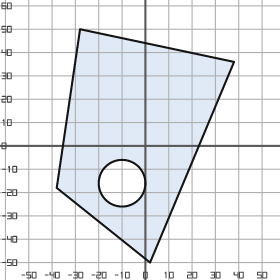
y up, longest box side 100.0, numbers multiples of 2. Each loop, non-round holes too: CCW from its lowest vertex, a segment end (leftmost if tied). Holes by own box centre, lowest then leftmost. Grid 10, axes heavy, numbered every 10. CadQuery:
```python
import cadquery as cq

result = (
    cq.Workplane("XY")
    .moveTo(2.0, -50.0)
    .lineTo(38.0, 36.0)
    .lineTo(-28.0, 50.0)
    .lineTo(-38.0, -18.0)
    .close()
    .moveTo(-10.0, -16.0)
    .circle(10.0)
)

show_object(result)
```